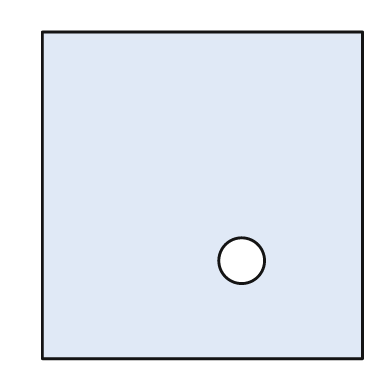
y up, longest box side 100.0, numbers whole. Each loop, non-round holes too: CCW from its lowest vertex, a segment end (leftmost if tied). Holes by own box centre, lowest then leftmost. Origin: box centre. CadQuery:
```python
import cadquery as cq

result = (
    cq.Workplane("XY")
    .moveTo(-49.0, -50.0)
    .lineTo(49.0, -50.0)
    .lineTo(49.0, 50.0)
    .lineTo(-49.0, 50.0)
    .close()
    .moveTo(12.0, -20.0)
    .circle(7.0)
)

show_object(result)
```